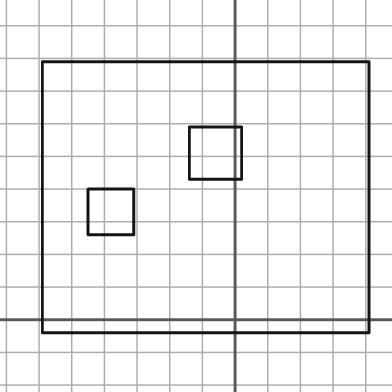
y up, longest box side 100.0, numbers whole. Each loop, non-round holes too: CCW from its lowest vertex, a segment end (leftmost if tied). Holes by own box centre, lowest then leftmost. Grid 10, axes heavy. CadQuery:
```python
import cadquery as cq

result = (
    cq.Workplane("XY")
    .moveTo(-59.0, -4.0)
    .lineTo(41.0, -4.0)
    .lineTo(41.0, 79.0)
    .lineTo(-59.0, 79.0)
    .close()
    .moveTo(-45.0, 26.0)
    .lineTo(-31.0, 26.0)
    .lineTo(-31.0, 40.0)
    .lineTo(-45.0, 40.0)
    .close()
    .moveTo(-14.0, 43.0)
    .lineTo(2.0, 43.0)
    .lineTo(2.0, 59.0)
    .lineTo(-14.0, 59.0)
    .close()
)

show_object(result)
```